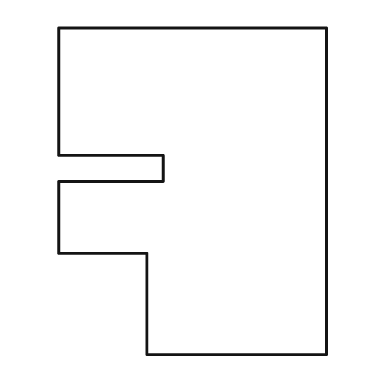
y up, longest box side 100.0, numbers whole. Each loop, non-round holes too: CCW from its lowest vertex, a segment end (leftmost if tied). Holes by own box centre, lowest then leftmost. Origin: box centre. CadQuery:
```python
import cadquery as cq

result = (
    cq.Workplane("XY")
    .moveTo(-14.0, -50.0)
    .lineTo(41.0, -50.0)
    .lineTo(41.0, 50.0)
    .lineTo(-41.0, 50.0)
    .lineTo(-41.0, 11.0)
    .lineTo(-9.0, 11.0)
    .lineTo(-9.0, 3.0)
    .lineTo(-41.0, 3.0)
    .lineTo(-41.0, -19.0)
    .lineTo(-14.0, -19.0)
    .close()
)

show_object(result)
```